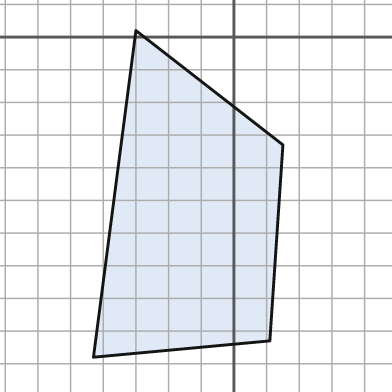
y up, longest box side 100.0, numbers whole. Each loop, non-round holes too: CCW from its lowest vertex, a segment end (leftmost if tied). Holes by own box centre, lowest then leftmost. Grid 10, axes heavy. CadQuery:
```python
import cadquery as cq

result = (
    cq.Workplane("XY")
    .moveTo(-43.0, -98.0)
    .lineTo(11.0, -93.0)
    .lineTo(15.0, -33.0)
    .lineTo(-30.0, 2.0)
    .close()
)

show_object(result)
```